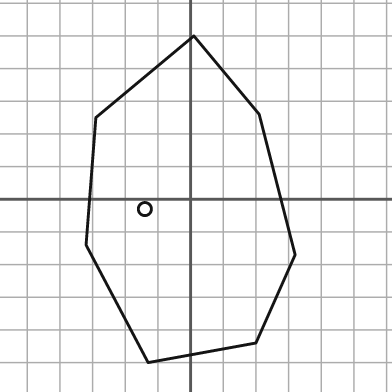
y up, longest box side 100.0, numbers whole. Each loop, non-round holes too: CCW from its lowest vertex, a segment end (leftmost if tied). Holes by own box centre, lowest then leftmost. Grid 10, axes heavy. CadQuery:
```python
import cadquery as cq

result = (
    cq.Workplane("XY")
    .moveTo(-13.0, -50.0)
    .lineTo(20.0, -44.0)
    .lineTo(32.0, -17.0)
    .lineTo(21.0, 26.0)
    .lineTo(1.0, 50.0)
    .lineTo(-29.0, 25.0)
    .lineTo(-32.0, -14.0)
    .close()
    .moveTo(-14.0, -3.0)
    .circle(2.0)
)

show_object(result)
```